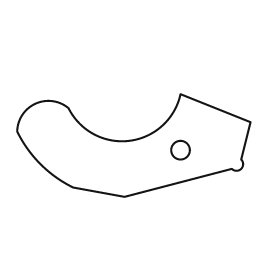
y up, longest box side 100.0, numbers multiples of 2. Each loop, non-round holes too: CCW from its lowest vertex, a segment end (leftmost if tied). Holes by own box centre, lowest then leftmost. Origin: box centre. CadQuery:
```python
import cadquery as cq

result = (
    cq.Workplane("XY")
    .moveTo(-4.0, -22.0)
    .lineTo(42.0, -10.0)
    .threePointArc((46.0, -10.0), (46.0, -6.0))
    .lineTo(50.0, 10.0)
    .lineTo(20.0, 22.0)
    .threePointArc((-2.0, 2.0), (-28.0, 16.0))
    .threePointArc((-42.0, 18.0), (-50.0, 6.0))
    .threePointArc((-40.0, -8.0), (-26.0, -18.0))
    .close()
    .moveTo(20.0, -2.0)
    .circle(4.0)
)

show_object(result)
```